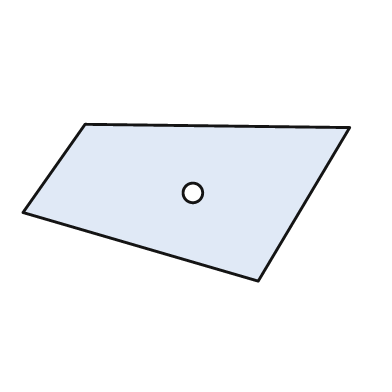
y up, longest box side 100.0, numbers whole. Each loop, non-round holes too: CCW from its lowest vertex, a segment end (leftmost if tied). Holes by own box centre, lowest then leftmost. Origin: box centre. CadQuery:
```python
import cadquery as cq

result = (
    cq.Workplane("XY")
    .moveTo(22.0, -24.0)
    .lineTo(50.0, 23.0)
    .lineTo(-31.0, 24.0)
    .lineTo(-50.0, -3.0)
    .close()
    .moveTo(2.0, 3.0)
    .circle(3.0)
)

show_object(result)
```